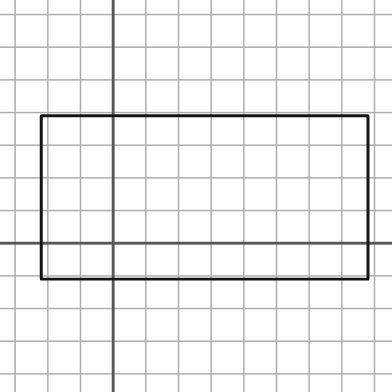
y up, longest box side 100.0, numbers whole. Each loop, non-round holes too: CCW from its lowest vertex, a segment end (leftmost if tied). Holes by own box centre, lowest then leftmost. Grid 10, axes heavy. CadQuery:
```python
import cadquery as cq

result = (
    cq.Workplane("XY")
    .moveTo(-22.0, -11.0)
    .lineTo(78.0, -11.0)
    .lineTo(78.0, 39.0)
    .lineTo(-22.0, 39.0)
    .close()
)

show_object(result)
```